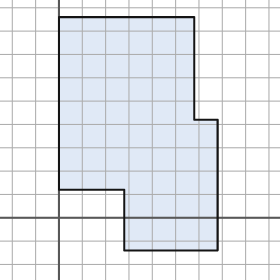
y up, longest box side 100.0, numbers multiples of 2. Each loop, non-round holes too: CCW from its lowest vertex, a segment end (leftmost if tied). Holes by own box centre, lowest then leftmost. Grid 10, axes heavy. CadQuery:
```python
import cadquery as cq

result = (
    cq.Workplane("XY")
    .moveTo(28.0, -14.0)
    .lineTo(68.0, -14.0)
    .lineTo(68.0, 42.0)
    .lineTo(58.0, 42.0)
    .lineTo(58.0, 86.0)
    .lineTo(0.0, 86.0)
    .lineTo(0.0, 12.0)
    .lineTo(28.0, 12.0)
    .close()
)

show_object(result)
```